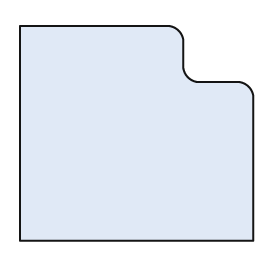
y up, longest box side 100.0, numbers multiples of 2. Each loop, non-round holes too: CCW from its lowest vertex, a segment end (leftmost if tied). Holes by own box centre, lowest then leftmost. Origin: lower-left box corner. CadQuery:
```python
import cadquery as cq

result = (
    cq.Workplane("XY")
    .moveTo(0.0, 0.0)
    .lineTo(100.0, 0.0)
    .lineTo(100.0, 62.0)
    .threePointArc((98.0, 66.0), (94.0, 68.0))
    .lineTo(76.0, 68.0)
    .threePointArc((72.0, 70.0), (70.0, 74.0))
    .lineTo(70.0, 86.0)
    .threePointArc((68.0, 90.0), (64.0, 92.0))
    .lineTo(0.0, 92.0)
    .close()
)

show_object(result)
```